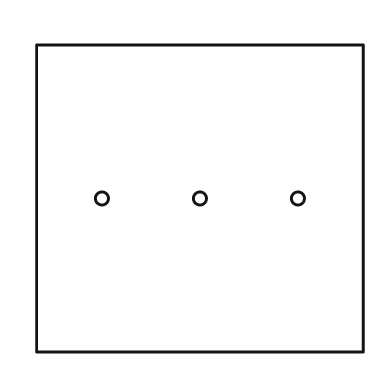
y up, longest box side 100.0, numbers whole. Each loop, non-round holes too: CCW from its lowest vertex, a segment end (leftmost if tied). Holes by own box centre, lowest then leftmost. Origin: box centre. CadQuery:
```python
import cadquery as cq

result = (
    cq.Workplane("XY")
    .moveTo(-50.0, -47.0)
    .lineTo(50.0, -47.0)
    .lineTo(50.0, 47.0)
    .lineTo(-50.0, 47.0)
    .close()
    .moveTo(-30.0, 0.0)
    .circle(2.0)
    .moveTo(0.0, 0.0)
    .circle(2.0)
    .moveTo(30.0, 0.0)
    .circle(2.0)
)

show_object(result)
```